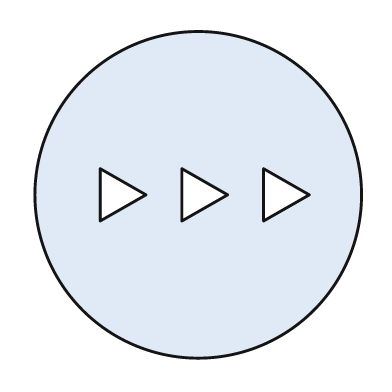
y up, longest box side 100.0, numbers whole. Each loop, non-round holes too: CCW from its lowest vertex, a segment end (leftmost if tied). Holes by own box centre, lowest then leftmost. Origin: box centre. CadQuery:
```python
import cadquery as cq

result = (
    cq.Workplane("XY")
    .moveTo(0.0, 0.0)
    .circle(50.0)
    .moveTo(-30.0, -8.0)
    .lineTo(-16.0, 0.0)
    .lineTo(-30.0, 8.0)
    .close()
    .moveTo(-5.0, -8.0)
    .lineTo(9.0, 0.0)
    .lineTo(-5.0, 8.0)
    .close()
    .moveTo(20.0, -8.0)
    .lineTo(34.0, 0.0)
    .lineTo(20.0, 8.0)
    .close()
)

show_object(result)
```